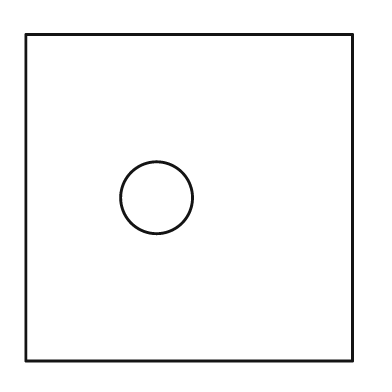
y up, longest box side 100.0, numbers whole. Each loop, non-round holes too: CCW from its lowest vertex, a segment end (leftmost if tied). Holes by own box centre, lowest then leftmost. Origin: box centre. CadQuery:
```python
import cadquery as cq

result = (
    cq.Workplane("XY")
    .moveTo(-50.0, -50.0)
    .lineTo(50.0, -50.0)
    .lineTo(50.0, 50.0)
    .lineTo(-50.0, 50.0)
    .close()
    .moveTo(-10.0, 0.0)
    .circle(11.0)
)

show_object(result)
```